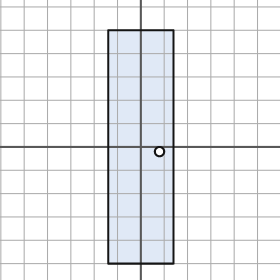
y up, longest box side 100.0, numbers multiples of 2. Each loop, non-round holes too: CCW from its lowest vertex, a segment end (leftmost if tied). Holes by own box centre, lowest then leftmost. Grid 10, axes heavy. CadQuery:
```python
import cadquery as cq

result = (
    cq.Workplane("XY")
    .moveTo(-14.0, -50.0)
    .lineTo(14.0, -50.0)
    .lineTo(14.0, 50.0)
    .lineTo(-14.0, 50.0)
    .close()
    .moveTo(8.0, -2.0)
    .circle(2.0)
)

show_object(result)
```